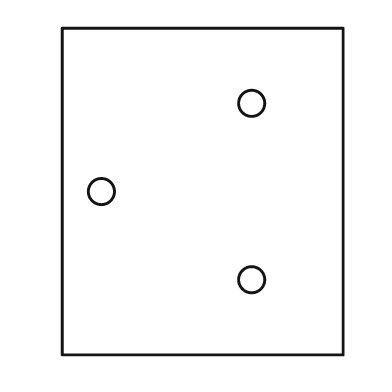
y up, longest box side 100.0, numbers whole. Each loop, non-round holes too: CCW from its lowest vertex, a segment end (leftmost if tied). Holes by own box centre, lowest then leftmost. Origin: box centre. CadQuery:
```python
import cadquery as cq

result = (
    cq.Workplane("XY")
    .moveTo(-43.0, -50.0)
    .lineTo(43.0, -50.0)
    .lineTo(43.0, 50.0)
    .lineTo(-43.0, 50.0)
    .close()
    .moveTo(15.0, -27.0)
    .circle(4.0)
    .moveTo(-31.0, 0.0)
    .circle(4.0)
    .moveTo(15.0, 27.0)
    .circle(4.0)
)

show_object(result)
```